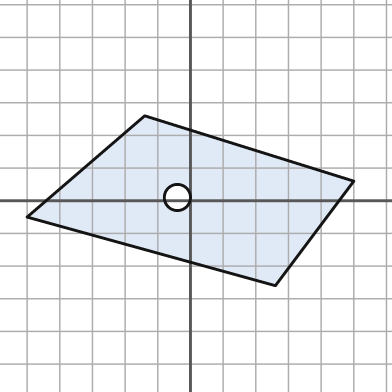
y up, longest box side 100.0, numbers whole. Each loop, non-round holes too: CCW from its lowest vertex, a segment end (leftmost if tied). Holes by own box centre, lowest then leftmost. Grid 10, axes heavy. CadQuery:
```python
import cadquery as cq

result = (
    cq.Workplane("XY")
    .moveTo(26.0, -26.0)
    .lineTo(50.0, 6.0)
    .lineTo(-14.0, 26.0)
    .lineTo(-50.0, -5.0)
    .close()
    .moveTo(-4.0, 1.0)
    .circle(4.0)
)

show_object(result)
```